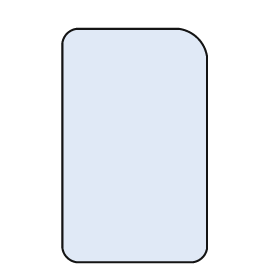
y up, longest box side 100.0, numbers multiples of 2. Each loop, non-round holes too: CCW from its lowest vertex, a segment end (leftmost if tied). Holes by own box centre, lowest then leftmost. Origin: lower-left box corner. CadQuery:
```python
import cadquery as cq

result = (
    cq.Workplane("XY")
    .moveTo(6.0, 0.0)
    .lineTo(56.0, 0.0)
    .threePointArc((60.0, 2.0), (62.0, 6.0))
    .lineTo(62.0, 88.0)
    .threePointArc((58.0, 96.0), (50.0, 100.0))
    .lineTo(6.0, 100.0)
    .threePointArc((2.0, 98.0), (0.0, 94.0))
    .lineTo(0.0, 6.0)
    .threePointArc((2.0, 2.0), (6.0, 0.0))
    .close()
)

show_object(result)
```